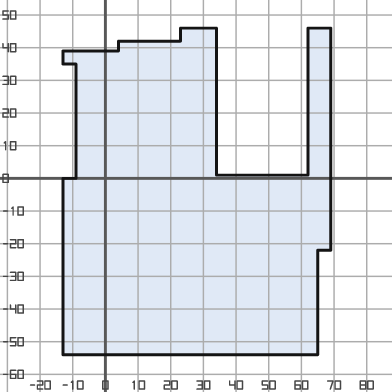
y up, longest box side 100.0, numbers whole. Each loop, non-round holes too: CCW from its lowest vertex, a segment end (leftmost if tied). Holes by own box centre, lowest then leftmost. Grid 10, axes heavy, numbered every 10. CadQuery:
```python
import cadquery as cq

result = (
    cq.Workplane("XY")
    .moveTo(-13.0, -54.0)
    .lineTo(65.0, -54.0)
    .lineTo(65.0, -22.0)
    .lineTo(69.0, -22.0)
    .lineTo(69.0, 46.0)
    .lineTo(62.0, 46.0)
    .lineTo(62.0, 1.0)
    .lineTo(34.0, 1.0)
    .lineTo(34.0, 46.0)
    .lineTo(23.0, 46.0)
    .lineTo(23.0, 42.0)
    .lineTo(4.0, 42.0)
    .lineTo(4.0, 39.0)
    .lineTo(-13.0, 39.0)
    .lineTo(-13.0, 35.0)
    .lineTo(-9.0, 35.0)
    .lineTo(-9.0, 0.0)
    .lineTo(-13.0, 0.0)
    .close()
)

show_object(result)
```